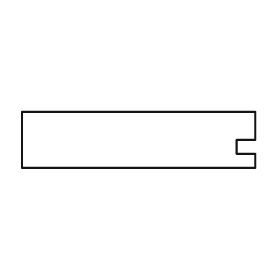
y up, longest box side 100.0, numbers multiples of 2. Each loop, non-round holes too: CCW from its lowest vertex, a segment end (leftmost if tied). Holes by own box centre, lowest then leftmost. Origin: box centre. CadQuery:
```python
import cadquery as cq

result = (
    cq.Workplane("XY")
    .moveTo(-50.0, -12.0)
    .lineTo(50.0, -12.0)
    .lineTo(50.0, -6.0)
    .lineTo(42.0, -6.0)
    .lineTo(42.0, 0.0)
    .lineTo(50.0, 0.0)
    .lineTo(50.0, 12.0)
    .lineTo(-50.0, 12.0)
    .close()
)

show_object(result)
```